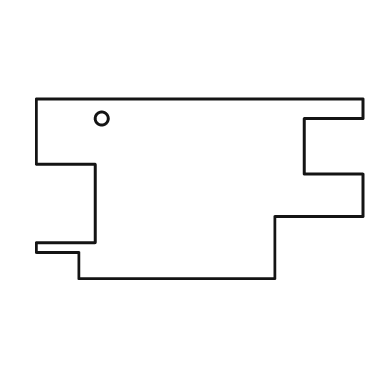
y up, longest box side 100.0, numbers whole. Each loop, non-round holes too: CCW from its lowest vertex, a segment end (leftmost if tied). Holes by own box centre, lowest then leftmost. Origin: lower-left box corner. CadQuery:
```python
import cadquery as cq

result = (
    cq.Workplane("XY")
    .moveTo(13.0, 0.0)
    .lineTo(73.0, 0.0)
    .lineTo(73.0, 19.0)
    .lineTo(100.0, 19.0)
    .lineTo(100.0, 32.0)
    .lineTo(82.0, 32.0)
    .lineTo(82.0, 49.0)
    .lineTo(100.0, 49.0)
    .lineTo(100.0, 55.0)
    .lineTo(0.0, 55.0)
    .lineTo(0.0, 35.0)
    .lineTo(18.0, 35.0)
    .lineTo(18.0, 11.0)
    .lineTo(0.0, 11.0)
    .lineTo(0.0, 8.0)
    .lineTo(13.0, 8.0)
    .close()
    .moveTo(20.0, 49.0)
    .circle(2.0)
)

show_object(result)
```